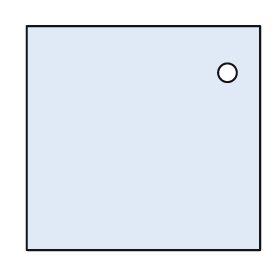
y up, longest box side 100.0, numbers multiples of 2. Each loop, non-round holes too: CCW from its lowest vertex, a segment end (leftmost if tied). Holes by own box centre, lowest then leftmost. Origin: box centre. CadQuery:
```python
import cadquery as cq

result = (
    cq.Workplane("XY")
    .moveTo(-50.0, -48.0)
    .lineTo(50.0, -48.0)
    .lineTo(50.0, 48.0)
    .lineTo(-50.0, 48.0)
    .close()
    .moveTo(36.0, 28.0)
    .circle(4.0)
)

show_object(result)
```